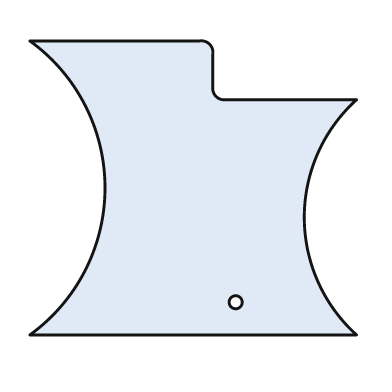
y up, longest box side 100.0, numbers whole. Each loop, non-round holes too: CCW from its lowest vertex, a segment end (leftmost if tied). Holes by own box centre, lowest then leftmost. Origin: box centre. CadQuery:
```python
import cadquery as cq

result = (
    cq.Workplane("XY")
    .moveTo(-50.0, -45.0)
    .lineTo(50.0, -45.0)
    .threePointArc((34.0, -9.0), (50.0, 27.0))
    .lineTo(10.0, 27.0)
    .threePointArc((7.0, 28.0), (6.0, 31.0))
    .lineTo(6.0, 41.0)
    .threePointArc((5.0, 44.0), (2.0, 45.0))
    .lineTo(-50.0, 45.0)
    .threePointArc((-27.0, 0.0), (-50.0, -45.0))
    .close()
    .moveTo(13.0, -35.0)
    .circle(2.0)
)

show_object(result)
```